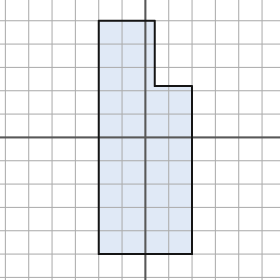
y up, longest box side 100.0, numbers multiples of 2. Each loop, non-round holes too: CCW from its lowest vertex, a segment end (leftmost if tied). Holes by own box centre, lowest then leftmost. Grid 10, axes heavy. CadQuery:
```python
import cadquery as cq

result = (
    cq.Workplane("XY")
    .moveTo(-20.0, -50.0)
    .lineTo(20.0, -50.0)
    .lineTo(20.0, 22.0)
    .lineTo(4.0, 22.0)
    .lineTo(4.0, 50.0)
    .lineTo(-20.0, 50.0)
    .close()
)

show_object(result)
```